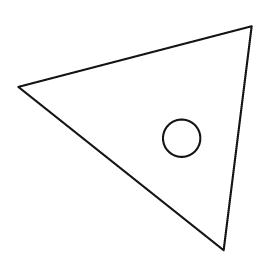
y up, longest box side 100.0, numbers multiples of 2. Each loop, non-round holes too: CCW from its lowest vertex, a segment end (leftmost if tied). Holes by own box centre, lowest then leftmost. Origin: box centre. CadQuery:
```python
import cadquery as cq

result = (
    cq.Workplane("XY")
    .moveTo(38.0, -48.0)
    .lineTo(50.0, 48.0)
    .lineTo(-50.0, 22.0)
    .close()
    .moveTo(20.0, 0.0)
    .circle(8.0)
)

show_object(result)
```